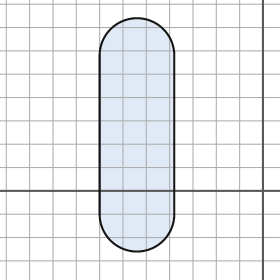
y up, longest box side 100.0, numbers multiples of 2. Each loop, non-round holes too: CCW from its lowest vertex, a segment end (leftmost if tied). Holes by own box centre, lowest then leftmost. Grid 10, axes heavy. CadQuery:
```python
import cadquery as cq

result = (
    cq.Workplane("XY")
    .moveTo(-70.0, -10.0)
    .threePointArc((-54.0, -26.0), (-38.0, -10.0))
    .lineTo(-38.0, 58.0)
    .threePointArc((-54.0, 74.0), (-70.0, 58.0))
    .close()
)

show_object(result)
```